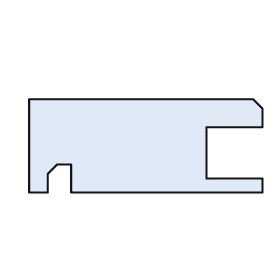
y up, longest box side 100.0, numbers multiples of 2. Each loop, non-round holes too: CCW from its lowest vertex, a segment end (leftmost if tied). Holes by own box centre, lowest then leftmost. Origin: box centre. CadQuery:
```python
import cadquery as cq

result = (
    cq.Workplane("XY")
    .moveTo(-50.0, -20.0)
    .lineTo(-42.0, -20.0)
    .lineTo(-42.0, -12.0)
    .lineTo(-38.0, -8.0)
    .lineTo(-32.0, -8.0)
    .lineTo(-32.0, -20.0)
    .lineTo(50.0, -20.0)
    .lineTo(50.0, -14.0)
    .lineTo(26.0, -14.0)
    .lineTo(26.0, 8.0)
    .lineTo(50.0, 8.0)
    .lineTo(50.0, 16.0)
    .lineTo(46.0, 20.0)
    .lineTo(-50.0, 20.0)
    .close()
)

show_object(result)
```